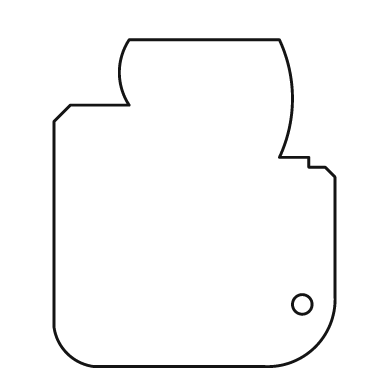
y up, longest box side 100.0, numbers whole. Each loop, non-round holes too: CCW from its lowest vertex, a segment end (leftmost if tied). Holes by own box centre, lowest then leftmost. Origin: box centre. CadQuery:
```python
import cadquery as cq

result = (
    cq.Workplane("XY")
    .moveTo(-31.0, -50.0)
    .lineTo(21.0, -50.0)
    .threePointArc((37.0, -44.0), (43.0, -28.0))
    .lineTo(43.0, 8.0)
    .lineTo(40.0, 11.0)
    .lineTo(35.0, 11.0)
    .lineTo(35.0, 14.0)
    .lineTo(26.0, 14.0)
    .threePointArc((30.0, 32.0), (26.0, 50.0))
    .lineTo(-20.0, 50.0)
    .threePointArc((-23.0, 40.0), (-20.0, 30.0))
    .lineTo(-38.0, 30.0)
    .lineTo(-43.0, 25.0)
    .lineTo(-43.0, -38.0)
    .threePointArc((-39.0, -46.0), (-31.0, -50.0))
    .close()
    .moveTo(33.0, -31.0)
    .circle(3.0)
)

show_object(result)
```